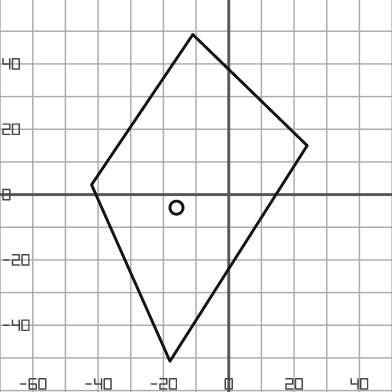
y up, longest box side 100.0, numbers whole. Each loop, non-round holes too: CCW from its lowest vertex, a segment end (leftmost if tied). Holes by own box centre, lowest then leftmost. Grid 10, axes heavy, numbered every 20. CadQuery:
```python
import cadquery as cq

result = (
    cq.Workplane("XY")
    .moveTo(-18.0, -51.0)
    .lineTo(24.0, 15.0)
    .lineTo(-11.0, 49.0)
    .lineTo(-42.0, 3.0)
    .close()
    .moveTo(-16.0, -4.0)
    .circle(2.0)
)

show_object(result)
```